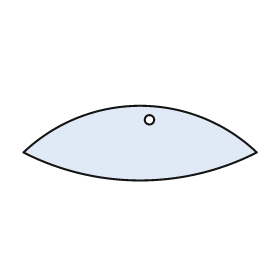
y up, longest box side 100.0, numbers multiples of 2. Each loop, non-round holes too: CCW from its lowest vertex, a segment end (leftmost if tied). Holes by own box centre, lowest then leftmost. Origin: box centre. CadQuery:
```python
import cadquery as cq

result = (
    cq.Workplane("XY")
    .moveTo(-50.0, -4.0)
    .threePointArc((0.0, -16.0), (50.0, -4.0))
    .threePointArc((0.0, 16.0), (-50.0, -4.0))
    .close()
    .moveTo(4.0, 10.0)
    .circle(2.0)
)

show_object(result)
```